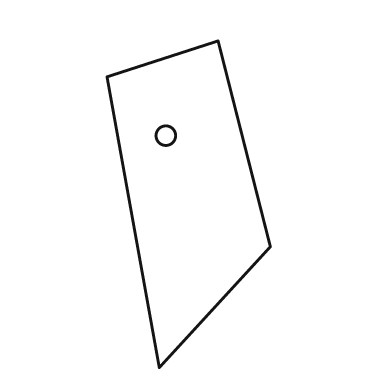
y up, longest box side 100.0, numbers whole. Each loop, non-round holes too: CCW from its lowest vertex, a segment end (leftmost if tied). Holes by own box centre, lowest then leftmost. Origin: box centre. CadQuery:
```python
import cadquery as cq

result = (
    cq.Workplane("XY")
    .moveTo(-9.0, -50.0)
    .lineTo(25.0, -13.0)
    .lineTo(9.0, 50.0)
    .lineTo(-25.0, 39.0)
    .close()
    .moveTo(-7.0, 21.0)
    .circle(3.0)
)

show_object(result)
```